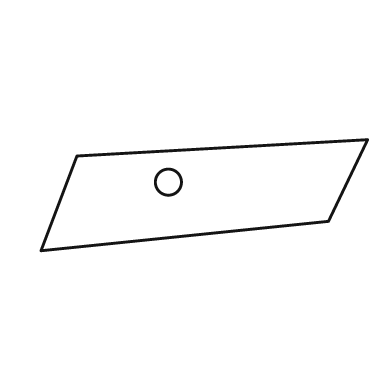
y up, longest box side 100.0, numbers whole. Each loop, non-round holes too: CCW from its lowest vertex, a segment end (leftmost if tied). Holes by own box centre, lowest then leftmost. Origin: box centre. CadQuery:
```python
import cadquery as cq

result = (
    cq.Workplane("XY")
    .moveTo(-50.0, -17.0)
    .lineTo(38.0, -8.0)
    .lineTo(50.0, 17.0)
    .lineTo(-39.0, 12.0)
    .close()
    .moveTo(-11.0, 4.0)
    .circle(4.0)
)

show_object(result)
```